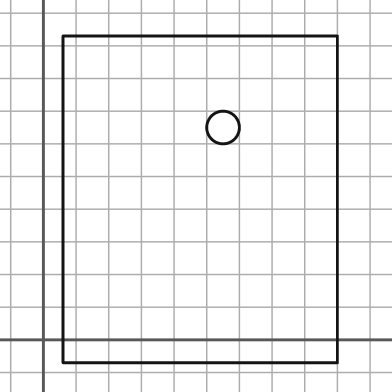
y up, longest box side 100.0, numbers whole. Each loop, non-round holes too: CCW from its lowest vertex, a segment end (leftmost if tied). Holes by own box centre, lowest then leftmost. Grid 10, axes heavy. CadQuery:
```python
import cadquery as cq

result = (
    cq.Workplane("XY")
    .moveTo(6.0, -7.0)
    .lineTo(90.0, -7.0)
    .lineTo(90.0, 93.0)
    .lineTo(6.0, 93.0)
    .close()
    .moveTo(55.0, 65.0)
    .circle(5.0)
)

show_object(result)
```